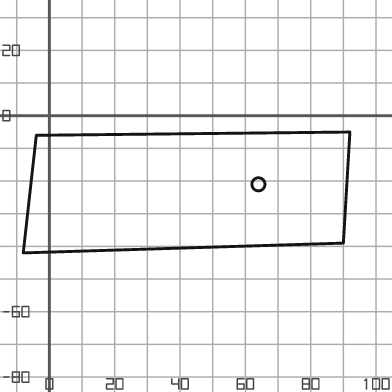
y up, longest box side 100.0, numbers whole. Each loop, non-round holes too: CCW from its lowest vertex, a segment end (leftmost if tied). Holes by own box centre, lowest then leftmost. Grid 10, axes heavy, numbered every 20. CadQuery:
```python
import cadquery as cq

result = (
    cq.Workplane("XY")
    .moveTo(-8.0, -42.0)
    .lineTo(90.0, -39.0)
    .lineTo(92.0, -5.0)
    .lineTo(-4.0, -6.0)
    .close()
    .moveTo(64.0, -21.0)
    .circle(2.0)
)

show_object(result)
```